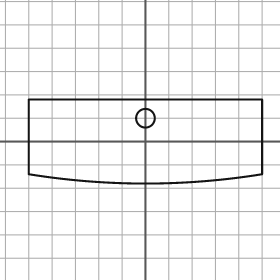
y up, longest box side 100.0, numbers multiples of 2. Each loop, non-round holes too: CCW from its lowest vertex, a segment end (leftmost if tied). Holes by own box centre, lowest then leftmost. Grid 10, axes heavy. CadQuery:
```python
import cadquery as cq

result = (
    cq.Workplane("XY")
    .moveTo(-50.0, -14.0)
    .threePointArc((0.0, -18.0), (50.0, -14.0))
    .lineTo(50.0, 18.0)
    .lineTo(-50.0, 18.0)
    .close()
    .moveTo(0.0, 10.0)
    .circle(4.0)
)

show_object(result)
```